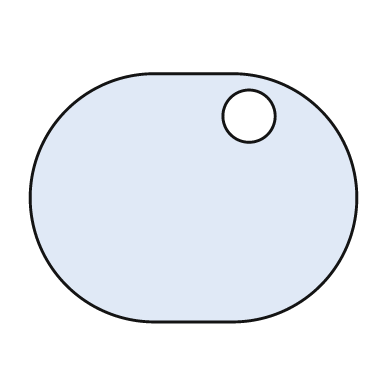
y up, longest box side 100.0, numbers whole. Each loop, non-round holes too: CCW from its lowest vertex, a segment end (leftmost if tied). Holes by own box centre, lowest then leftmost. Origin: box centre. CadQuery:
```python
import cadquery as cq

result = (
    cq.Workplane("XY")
    .moveTo(-12.0, -38.0)
    .lineTo(12.0, -38.0)
    .threePointArc((50.0, 0.0), (12.0, 38.0))
    .lineTo(-12.0, 38.0)
    .threePointArc((-50.0, 0.0), (-12.0, -38.0))
    .close()
    .moveTo(17.0, 25.0)
    .circle(8.0)
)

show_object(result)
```